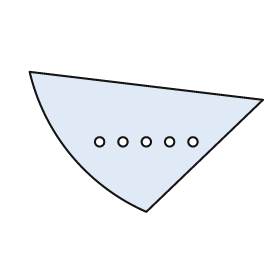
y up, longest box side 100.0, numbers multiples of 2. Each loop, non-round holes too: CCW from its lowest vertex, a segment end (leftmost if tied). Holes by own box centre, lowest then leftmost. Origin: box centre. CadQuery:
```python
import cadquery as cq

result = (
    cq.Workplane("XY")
    .moveTo(0.0, -30.0)
    .lineTo(50.0, 18.0)
    .lineTo(-50.0, 30.0)
    .threePointArc((-32.0, -6.0), (0.0, -30.0))
    .close()
    .moveTo(-20.0, 0.0)
    .circle(2.0)
    .moveTo(-10.0, 0.0)
    .circle(2.0)
    .moveTo(0.0, 0.0)
    .circle(2.0)
    .moveTo(10.0, 0.0)
    .circle(2.0)
    .moveTo(20.0, 0.0)
    .circle(2.0)
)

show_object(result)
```